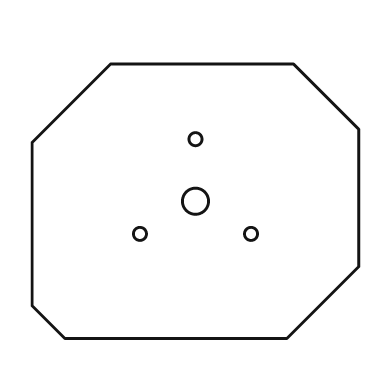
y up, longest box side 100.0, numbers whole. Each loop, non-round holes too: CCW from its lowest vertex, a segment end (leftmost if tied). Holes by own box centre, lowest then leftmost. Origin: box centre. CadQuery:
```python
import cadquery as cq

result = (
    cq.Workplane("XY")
    .moveTo(-40.0, -42.0)
    .lineTo(28.0, -42.0)
    .lineTo(50.0, -20.0)
    .lineTo(50.0, 22.0)
    .lineTo(30.0, 42.0)
    .lineTo(-26.0, 42.0)
    .lineTo(-50.0, 18.0)
    .lineTo(-50.0, -32.0)
    .close()
    .moveTo(-17.0, -10.0)
    .circle(2.0)
    .moveTo(17.0, -10.0)
    .circle(2.0)
    .moveTo(0.0, 0.0)
    .circle(4.0)
    .moveTo(0.0, 19.0)
    .circle(2.0)
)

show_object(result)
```